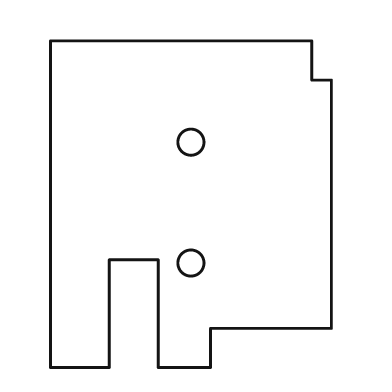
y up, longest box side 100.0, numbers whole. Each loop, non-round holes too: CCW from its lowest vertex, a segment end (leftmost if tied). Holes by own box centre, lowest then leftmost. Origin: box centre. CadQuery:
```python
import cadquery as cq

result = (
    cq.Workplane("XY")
    .moveTo(-43.0, -50.0)
    .lineTo(-25.0, -50.0)
    .lineTo(-25.0, -17.0)
    .lineTo(-10.0, -17.0)
    .lineTo(-10.0, -50.0)
    .lineTo(6.0, -50.0)
    .lineTo(6.0, -38.0)
    .lineTo(43.0, -38.0)
    .lineTo(43.0, 38.0)
    .lineTo(37.0, 38.0)
    .lineTo(37.0, 50.0)
    .lineTo(-43.0, 50.0)
    .close()
    .moveTo(0.0, -18.0)
    .circle(4.0)
    .moveTo(0.0, 19.0)
    .circle(4.0)
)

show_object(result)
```